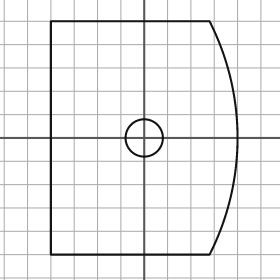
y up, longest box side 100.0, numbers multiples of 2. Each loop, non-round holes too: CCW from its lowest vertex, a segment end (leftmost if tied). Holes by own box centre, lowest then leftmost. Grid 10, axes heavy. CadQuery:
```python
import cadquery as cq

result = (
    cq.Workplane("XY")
    .moveTo(-40.0, -50.0)
    .lineTo(28.0, -50.0)
    .threePointArc((40.0, 0.0), (28.0, 50.0))
    .lineTo(-40.0, 50.0)
    .close()
    .moveTo(0.0, 0.0)
    .circle(8.0)
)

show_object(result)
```